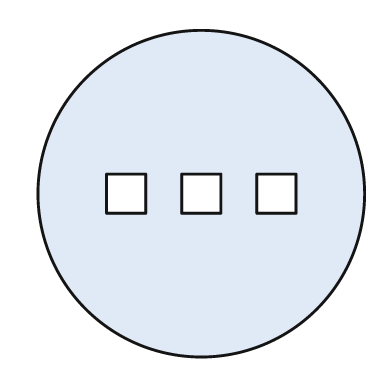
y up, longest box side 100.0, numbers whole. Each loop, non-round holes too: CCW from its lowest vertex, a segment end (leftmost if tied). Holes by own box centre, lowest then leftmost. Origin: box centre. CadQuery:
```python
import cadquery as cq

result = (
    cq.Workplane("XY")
    .moveTo(0.0, 0.0)
    .circle(50.0)
    .moveTo(-29.0, -6.0)
    .lineTo(-17.0, -6.0)
    .lineTo(-17.0, 6.0)
    .lineTo(-29.0, 6.0)
    .close()
    .moveTo(-6.0, -6.0)
    .lineTo(6.0, -6.0)
    .lineTo(6.0, 6.0)
    .lineTo(-6.0, 6.0)
    .close()
    .moveTo(17.0, -6.0)
    .lineTo(29.0, -6.0)
    .lineTo(29.0, 6.0)
    .lineTo(17.0, 6.0)
    .close()
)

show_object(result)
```